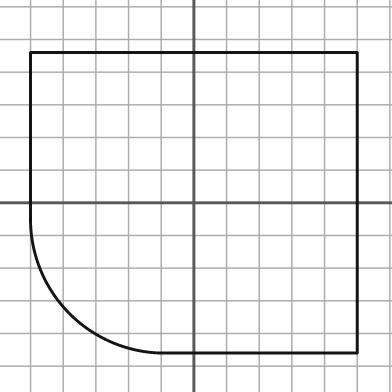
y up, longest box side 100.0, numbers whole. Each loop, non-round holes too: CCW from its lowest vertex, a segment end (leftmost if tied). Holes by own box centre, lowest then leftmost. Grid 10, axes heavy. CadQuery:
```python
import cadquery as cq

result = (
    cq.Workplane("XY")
    .moveTo(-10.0, -46.0)
    .lineTo(50.0, -46.0)
    .lineTo(50.0, 46.0)
    .lineTo(-50.0, 46.0)
    .lineTo(-50.0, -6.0)
    .threePointArc((-38.0, -34.0), (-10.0, -46.0))
    .close()
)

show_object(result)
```